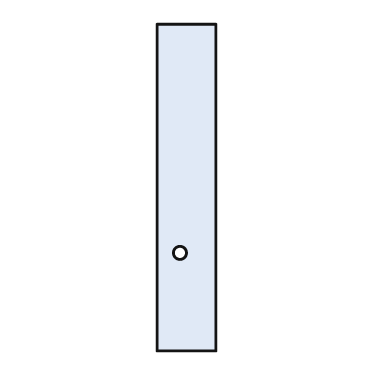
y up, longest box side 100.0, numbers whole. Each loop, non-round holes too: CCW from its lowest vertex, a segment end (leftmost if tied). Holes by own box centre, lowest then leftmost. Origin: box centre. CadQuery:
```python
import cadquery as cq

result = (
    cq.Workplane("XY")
    .moveTo(-9.0, -50.0)
    .lineTo(9.0, -50.0)
    .lineTo(9.0, 50.0)
    .lineTo(-9.0, 50.0)
    .close()
    .moveTo(-2.0, -20.0)
    .circle(2.0)
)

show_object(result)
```